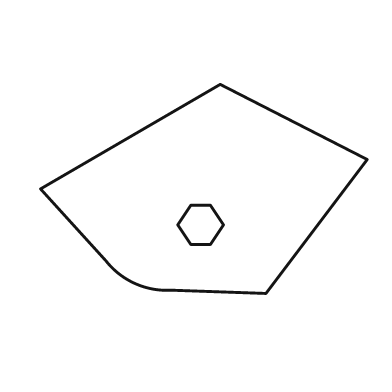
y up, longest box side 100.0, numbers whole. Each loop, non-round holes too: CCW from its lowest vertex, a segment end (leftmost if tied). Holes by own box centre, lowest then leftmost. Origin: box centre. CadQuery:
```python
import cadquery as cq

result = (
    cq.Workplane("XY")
    .moveTo(19.0, -32.0)
    .lineTo(50.0, 9.0)
    .lineTo(5.0, 32.0)
    .lineTo(-50.0, 0.0)
    .lineTo(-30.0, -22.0)
    .threePointArc((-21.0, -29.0), (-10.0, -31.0))
    .close()
    .moveTo(-4.0, -17.0)
    .lineTo(2.0, -17.0)
    .lineTo(6.0, -11.0)
    .lineTo(2.0, -5.0)
    .lineTo(-4.0, -5.0)
    .lineTo(-8.0, -11.0)
    .close()
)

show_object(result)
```